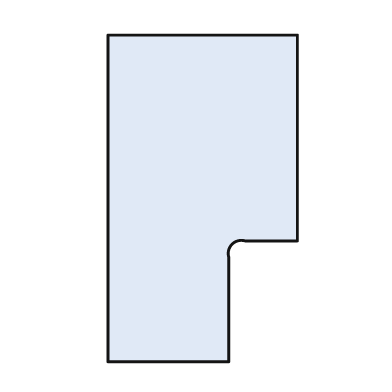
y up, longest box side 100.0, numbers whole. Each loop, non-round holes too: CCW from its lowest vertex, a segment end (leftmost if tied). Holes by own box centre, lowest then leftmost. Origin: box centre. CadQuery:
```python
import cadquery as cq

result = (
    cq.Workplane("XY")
    .moveTo(-29.0, -50.0)
    .lineTo(8.0, -50.0)
    .lineTo(8.0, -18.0)
    .threePointArc((9.0, -14.0), (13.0, -13.0))
    .lineTo(29.0, -13.0)
    .lineTo(29.0, 50.0)
    .lineTo(-29.0, 50.0)
    .close()
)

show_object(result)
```